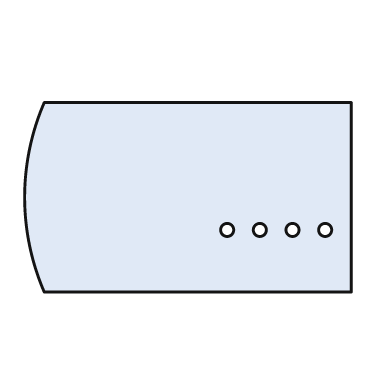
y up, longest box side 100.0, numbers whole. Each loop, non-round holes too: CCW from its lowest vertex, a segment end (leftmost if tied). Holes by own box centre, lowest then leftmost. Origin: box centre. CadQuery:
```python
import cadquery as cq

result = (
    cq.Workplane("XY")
    .moveTo(-44.0, -29.0)
    .lineTo(50.0, -29.0)
    .lineTo(50.0, 29.0)
    .lineTo(-44.0, 29.0)
    .threePointArc((-50.0, 0.0), (-44.0, -29.0))
    .close()
    .moveTo(12.0, -10.0)
    .circle(2.0)
    .moveTo(22.0, -10.0)
    .circle(2.0)
    .moveTo(32.0, -10.0)
    .circle(2.0)
    .moveTo(42.0, -10.0)
    .circle(2.0)
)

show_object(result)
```